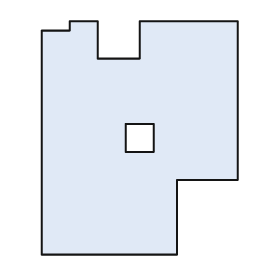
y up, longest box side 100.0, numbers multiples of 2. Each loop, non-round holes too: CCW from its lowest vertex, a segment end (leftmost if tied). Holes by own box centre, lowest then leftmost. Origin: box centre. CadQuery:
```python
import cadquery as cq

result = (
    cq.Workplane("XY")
    .moveTo(-42.0, -50.0)
    .lineTo(16.0, -50.0)
    .lineTo(16.0, -18.0)
    .lineTo(42.0, -18.0)
    .lineTo(42.0, 50.0)
    .lineTo(0.0, 50.0)
    .lineTo(0.0, 34.0)
    .lineTo(-18.0, 34.0)
    .lineTo(-18.0, 50.0)
    .lineTo(-30.0, 50.0)
    .lineTo(-30.0, 46.0)
    .lineTo(-42.0, 46.0)
    .close()
    .moveTo(-6.0, -6.0)
    .lineTo(6.0, -6.0)
    .lineTo(6.0, 6.0)
    .lineTo(-6.0, 6.0)
    .close()
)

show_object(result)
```